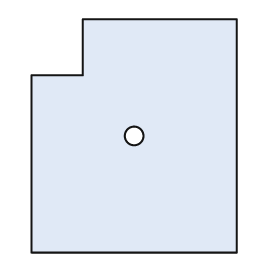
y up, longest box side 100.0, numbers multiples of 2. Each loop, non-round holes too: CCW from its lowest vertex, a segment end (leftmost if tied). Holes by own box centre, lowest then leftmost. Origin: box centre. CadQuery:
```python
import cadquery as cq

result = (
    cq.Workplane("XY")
    .moveTo(-44.0, -50.0)
    .lineTo(44.0, -50.0)
    .lineTo(44.0, 50.0)
    .lineTo(-22.0, 50.0)
    .lineTo(-22.0, 26.0)
    .lineTo(-44.0, 26.0)
    .close()
    .moveTo(0.0, 0.0)
    .circle(4.0)
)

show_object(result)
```